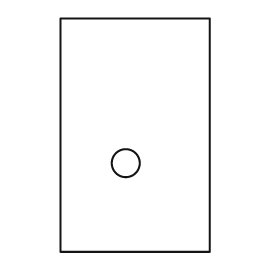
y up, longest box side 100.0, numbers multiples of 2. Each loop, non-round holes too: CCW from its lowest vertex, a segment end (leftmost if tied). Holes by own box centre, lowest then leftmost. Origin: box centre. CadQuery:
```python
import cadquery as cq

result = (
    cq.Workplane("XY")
    .moveTo(-32.0, -50.0)
    .lineTo(32.0, -50.0)
    .lineTo(32.0, 50.0)
    .lineTo(-32.0, 50.0)
    .close()
    .moveTo(-4.0, -12.0)
    .circle(6.0)
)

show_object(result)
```